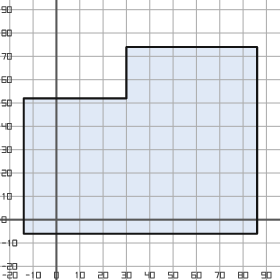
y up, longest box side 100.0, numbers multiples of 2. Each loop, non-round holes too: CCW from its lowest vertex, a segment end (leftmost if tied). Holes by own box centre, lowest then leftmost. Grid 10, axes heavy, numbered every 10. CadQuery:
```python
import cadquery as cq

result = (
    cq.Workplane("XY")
    .moveTo(-14.0, -6.0)
    .lineTo(86.0, -6.0)
    .lineTo(86.0, 74.0)
    .lineTo(30.0, 74.0)
    .lineTo(30.0, 52.0)
    .lineTo(-14.0, 52.0)
    .close()
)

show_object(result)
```